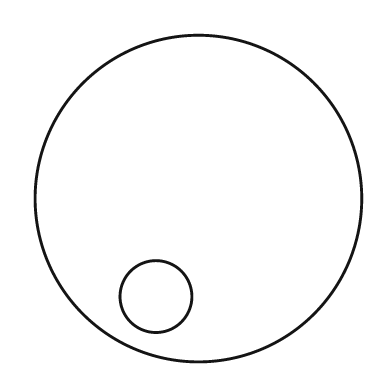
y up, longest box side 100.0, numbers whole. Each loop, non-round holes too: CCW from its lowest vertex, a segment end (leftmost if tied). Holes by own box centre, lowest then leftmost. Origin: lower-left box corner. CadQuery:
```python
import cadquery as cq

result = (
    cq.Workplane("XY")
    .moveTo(50.0, 50.0)
    .circle(50.0)
    .moveTo(37.0, 20.0)
    .circle(11.0)
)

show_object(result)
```